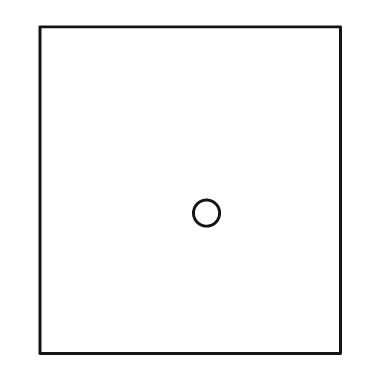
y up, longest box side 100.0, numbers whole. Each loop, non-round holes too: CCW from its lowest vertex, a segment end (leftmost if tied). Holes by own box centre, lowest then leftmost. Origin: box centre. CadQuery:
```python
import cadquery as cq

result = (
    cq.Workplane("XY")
    .moveTo(-46.0, -50.0)
    .lineTo(46.0, -50.0)
    .lineTo(46.0, 50.0)
    .lineTo(-46.0, 50.0)
    .close()
    .moveTo(5.0, -7.0)
    .circle(4.0)
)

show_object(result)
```